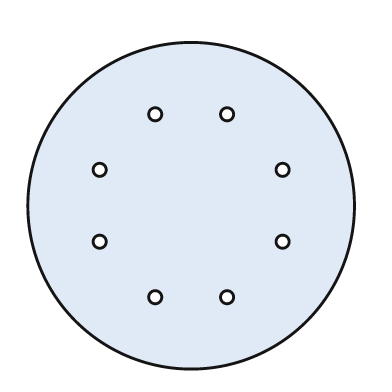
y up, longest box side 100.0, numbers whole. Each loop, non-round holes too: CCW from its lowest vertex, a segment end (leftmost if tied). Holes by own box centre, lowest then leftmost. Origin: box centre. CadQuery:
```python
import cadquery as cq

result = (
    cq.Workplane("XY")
    .moveTo(0.0, 0.0)
    .circle(50.0)
    .moveTo(-11.0, -28.0)
    .circle(2.0)
    .moveTo(11.0, -28.0)
    .circle(2.0)
    .moveTo(-28.0, -11.0)
    .circle(2.0)
    .moveTo(28.0, -11.0)
    .circle(2.0)
    .moveTo(-28.0, 11.0)
    .circle(2.0)
    .moveTo(28.0, 11.0)
    .circle(2.0)
    .moveTo(-11.0, 28.0)
    .circle(2.0)
    .moveTo(11.0, 28.0)
    .circle(2.0)
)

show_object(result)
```